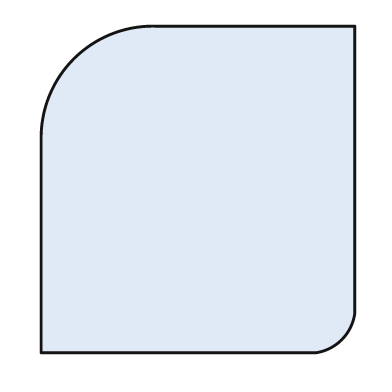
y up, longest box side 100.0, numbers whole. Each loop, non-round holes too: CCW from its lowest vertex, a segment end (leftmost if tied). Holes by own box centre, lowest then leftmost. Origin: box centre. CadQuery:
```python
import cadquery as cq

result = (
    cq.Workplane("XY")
    .moveTo(-48.0, -50.0)
    .lineTo(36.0, -50.0)
    .threePointArc((44.0, -46.0), (48.0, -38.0))
    .lineTo(48.0, 50.0)
    .lineTo(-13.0, 50.0)
    .threePointArc((-38.0, 40.0), (-48.0, 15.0))
    .close()
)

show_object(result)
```